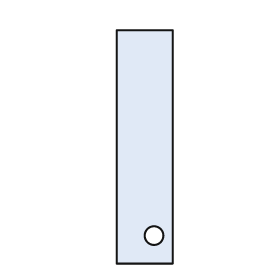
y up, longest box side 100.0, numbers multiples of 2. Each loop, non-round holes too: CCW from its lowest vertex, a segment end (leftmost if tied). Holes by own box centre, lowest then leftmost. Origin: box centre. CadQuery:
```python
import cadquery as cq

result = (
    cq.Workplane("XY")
    .moveTo(-12.0, -50.0)
    .lineTo(12.0, -50.0)
    .lineTo(12.0, 50.0)
    .lineTo(-12.0, 50.0)
    .close()
    .moveTo(4.0, -38.0)
    .circle(4.0)
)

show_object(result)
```